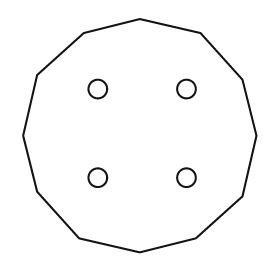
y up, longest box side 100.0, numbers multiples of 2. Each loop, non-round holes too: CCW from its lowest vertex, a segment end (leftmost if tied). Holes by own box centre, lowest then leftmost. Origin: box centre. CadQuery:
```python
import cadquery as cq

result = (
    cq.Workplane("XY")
    .moveTo(0.0, -50.0)
    .lineTo(24.0, -44.0)
    .lineTo(44.0, -26.0)
    .lineTo(50.0, 0.0)
    .lineTo(44.0, 24.0)
    .lineTo(26.0, 44.0)
    .lineTo(0.0, 50.0)
    .lineTo(-24.0, 44.0)
    .lineTo(-44.0, 26.0)
    .lineTo(-50.0, 0.0)
    .lineTo(-44.0, -24.0)
    .lineTo(-26.0, -44.0)
    .close()
    .moveTo(-18.0, -18.0)
    .circle(4.0)
    .moveTo(20.0, -18.0)
    .circle(4.0)
    .moveTo(-18.0, 20.0)
    .circle(4.0)
    .moveTo(20.0, 20.0)
    .circle(4.0)
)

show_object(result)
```